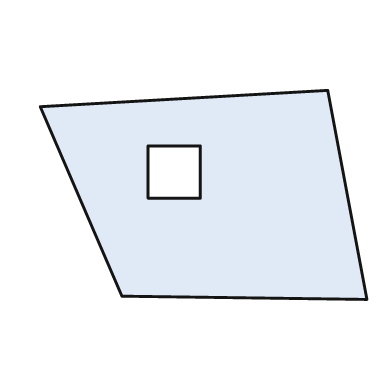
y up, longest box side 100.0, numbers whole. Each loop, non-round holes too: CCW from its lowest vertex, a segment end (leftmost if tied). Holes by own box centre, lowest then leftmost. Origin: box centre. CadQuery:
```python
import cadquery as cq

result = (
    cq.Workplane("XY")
    .moveTo(50.0, -32.0)
    .lineTo(38.0, 32.0)
    .lineTo(-50.0, 27.0)
    .lineTo(-25.0, -31.0)
    .close()
    .moveTo(-17.0, -1.0)
    .lineTo(-1.0, -1.0)
    .lineTo(-1.0, 15.0)
    .lineTo(-17.0, 15.0)
    .close()
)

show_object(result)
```